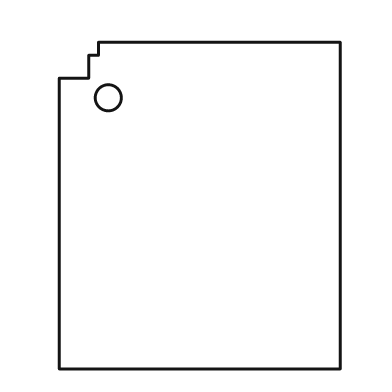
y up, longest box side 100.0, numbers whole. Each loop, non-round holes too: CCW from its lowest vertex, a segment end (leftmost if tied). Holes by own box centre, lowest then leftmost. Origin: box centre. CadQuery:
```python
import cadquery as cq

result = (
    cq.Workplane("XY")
    .moveTo(-43.0, -50.0)
    .lineTo(43.0, -50.0)
    .lineTo(43.0, 50.0)
    .lineTo(-31.0, 50.0)
    .lineTo(-31.0, 46.0)
    .lineTo(-34.0, 46.0)
    .lineTo(-34.0, 39.0)
    .lineTo(-43.0, 39.0)
    .close()
    .moveTo(-28.0, 33.0)
    .circle(4.0)
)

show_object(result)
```